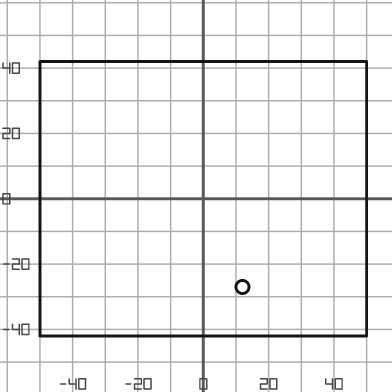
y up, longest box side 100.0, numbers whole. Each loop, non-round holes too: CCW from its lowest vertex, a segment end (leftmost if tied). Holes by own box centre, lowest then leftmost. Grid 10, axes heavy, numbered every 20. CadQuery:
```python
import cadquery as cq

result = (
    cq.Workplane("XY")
    .moveTo(-50.0, -42.0)
    .lineTo(50.0, -42.0)
    .lineTo(50.0, 42.0)
    .lineTo(-50.0, 42.0)
    .close()
    .moveTo(12.0, -27.0)
    .circle(2.0)
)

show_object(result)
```